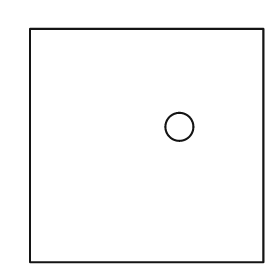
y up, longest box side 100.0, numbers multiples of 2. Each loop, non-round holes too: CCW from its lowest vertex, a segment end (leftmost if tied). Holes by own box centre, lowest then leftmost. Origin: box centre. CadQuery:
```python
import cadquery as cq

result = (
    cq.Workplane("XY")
    .moveTo(-50.0, -50.0)
    .lineTo(50.0, -50.0)
    .lineTo(50.0, 50.0)
    .lineTo(-50.0, 50.0)
    .close()
    .moveTo(14.0, 8.0)
    .circle(6.0)
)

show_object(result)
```